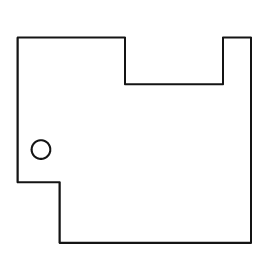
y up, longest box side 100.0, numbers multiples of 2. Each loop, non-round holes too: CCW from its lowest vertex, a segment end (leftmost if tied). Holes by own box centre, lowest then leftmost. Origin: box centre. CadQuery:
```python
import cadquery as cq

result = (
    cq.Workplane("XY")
    .moveTo(-32.0, -44.0)
    .lineTo(50.0, -44.0)
    .lineTo(50.0, 44.0)
    .lineTo(38.0, 44.0)
    .lineTo(38.0, 24.0)
    .lineTo(-4.0, 24.0)
    .lineTo(-4.0, 44.0)
    .lineTo(-50.0, 44.0)
    .lineTo(-50.0, -18.0)
    .lineTo(-32.0, -18.0)
    .close()
    .moveTo(-40.0, -4.0)
    .circle(4.0)
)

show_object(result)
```